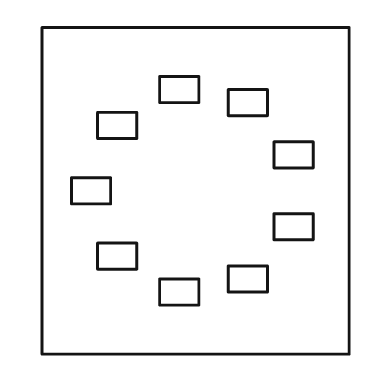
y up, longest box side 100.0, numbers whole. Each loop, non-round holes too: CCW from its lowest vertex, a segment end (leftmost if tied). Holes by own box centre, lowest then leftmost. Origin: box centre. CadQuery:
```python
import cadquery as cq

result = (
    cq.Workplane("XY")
    .moveTo(-47.0, -50.0)
    .lineTo(47.0, -50.0)
    .lineTo(47.0, 50.0)
    .lineTo(-47.0, 50.0)
    .close()
    .moveTo(-11.0, -35.0)
    .lineTo(1.0, -35.0)
    .lineTo(1.0, -27.0)
    .lineTo(-11.0, -27.0)
    .close()
    .moveTo(10.0, -31.0)
    .lineTo(22.0, -31.0)
    .lineTo(22.0, -23.0)
    .lineTo(10.0, -23.0)
    .close()
    .moveTo(-30.0, -24.0)
    .lineTo(-18.0, -24.0)
    .lineTo(-18.0, -16.0)
    .lineTo(-30.0, -16.0)
    .close()
    .moveTo(24.0, -15.0)
    .lineTo(36.0, -15.0)
    .lineTo(36.0, -7.0)
    .lineTo(24.0, -7.0)
    .close()
    .moveTo(-38.0, -4.0)
    .lineTo(-26.0, -4.0)
    .lineTo(-26.0, 4.0)
    .lineTo(-38.0, 4.0)
    .close()
    .moveTo(24.0, 7.0)
    .lineTo(36.0, 7.0)
    .lineTo(36.0, 15.0)
    .lineTo(24.0, 15.0)
    .close()
    .moveTo(-30.0, 16.0)
    .lineTo(-18.0, 16.0)
    .lineTo(-18.0, 24.0)
    .lineTo(-30.0, 24.0)
    .close()
    .moveTo(10.0, 23.0)
    .lineTo(22.0, 23.0)
    .lineTo(22.0, 31.0)
    .lineTo(10.0, 31.0)
    .close()
    .moveTo(-11.0, 27.0)
    .lineTo(1.0, 27.0)
    .lineTo(1.0, 35.0)
    .lineTo(-11.0, 35.0)
    .close()
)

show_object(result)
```